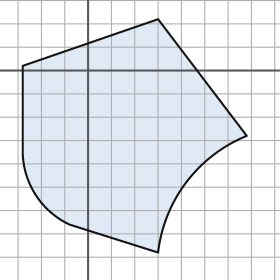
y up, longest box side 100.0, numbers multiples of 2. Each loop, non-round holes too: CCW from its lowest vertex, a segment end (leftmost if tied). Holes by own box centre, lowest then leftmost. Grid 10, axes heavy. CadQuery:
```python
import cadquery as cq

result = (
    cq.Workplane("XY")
    .moveTo(30.0, -78.0)
    .threePointArc((42.0, -48.0), (68.0, -28.0))
    .lineTo(30.0, 22.0)
    .lineTo(-28.0, 2.0)
    .lineTo(-28.0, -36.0)
    .threePointArc((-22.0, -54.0), (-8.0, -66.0))
    .close()
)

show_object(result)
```